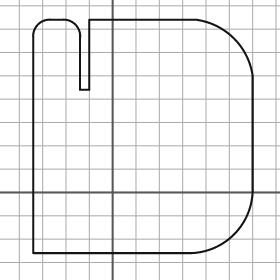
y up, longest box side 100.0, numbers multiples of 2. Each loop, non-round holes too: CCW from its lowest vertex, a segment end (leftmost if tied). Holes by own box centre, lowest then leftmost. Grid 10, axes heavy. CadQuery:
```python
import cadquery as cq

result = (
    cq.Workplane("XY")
    .moveTo(-34.0, -26.0)
    .lineTo(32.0, -26.0)
    .threePointArc((52.0, -18.0), (60.0, 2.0))
    .lineTo(60.0, 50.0)
    .threePointArc((52.0, 66.0), (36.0, 74.0))
    .lineTo(-10.0, 74.0)
    .lineTo(-10.0, 44.0)
    .lineTo(-14.0, 44.0)
    .lineTo(-14.0, 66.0)
    .threePointArc((-16.0, 72.0), (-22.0, 74.0))
    .lineTo(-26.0, 74.0)
    .threePointArc((-32.0, 72.0), (-34.0, 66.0))
    .close()
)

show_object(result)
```